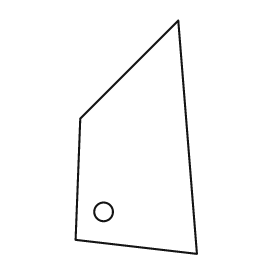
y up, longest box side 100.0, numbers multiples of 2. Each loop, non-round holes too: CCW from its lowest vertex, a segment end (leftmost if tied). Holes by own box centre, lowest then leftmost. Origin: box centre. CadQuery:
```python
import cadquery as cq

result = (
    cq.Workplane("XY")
    .moveTo(26.0, -50.0)
    .lineTo(18.0, 50.0)
    .lineTo(-24.0, 8.0)
    .lineTo(-26.0, -44.0)
    .close()
    .moveTo(-14.0, -32.0)
    .circle(4.0)
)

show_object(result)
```